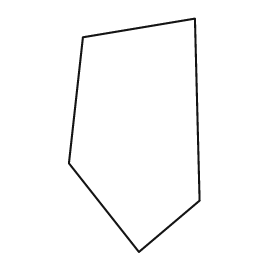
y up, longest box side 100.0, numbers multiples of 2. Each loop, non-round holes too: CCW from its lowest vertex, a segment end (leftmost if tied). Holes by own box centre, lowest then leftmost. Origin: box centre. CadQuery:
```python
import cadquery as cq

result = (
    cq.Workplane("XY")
    .moveTo(2.0, -50.0)
    .lineTo(28.0, -28.0)
    .lineTo(26.0, 50.0)
    .lineTo(-22.0, 42.0)
    .lineTo(-28.0, -12.0)
    .close()
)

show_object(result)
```